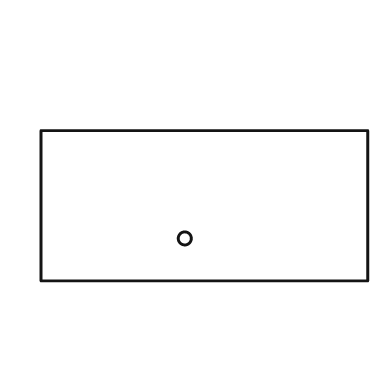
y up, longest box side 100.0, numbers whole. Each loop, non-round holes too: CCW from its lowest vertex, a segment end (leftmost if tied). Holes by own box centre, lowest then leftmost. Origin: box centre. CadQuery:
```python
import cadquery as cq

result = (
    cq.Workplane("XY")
    .moveTo(-50.0, -23.0)
    .lineTo(50.0, -23.0)
    .lineTo(50.0, 23.0)
    .lineTo(-50.0, 23.0)
    .close()
    .moveTo(-6.0, -10.0)
    .circle(2.0)
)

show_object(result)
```